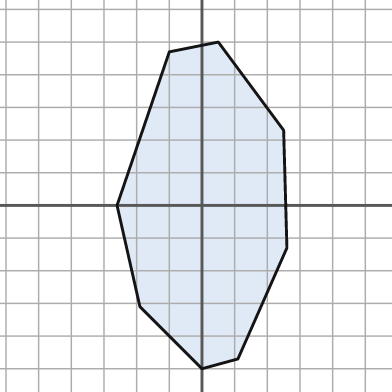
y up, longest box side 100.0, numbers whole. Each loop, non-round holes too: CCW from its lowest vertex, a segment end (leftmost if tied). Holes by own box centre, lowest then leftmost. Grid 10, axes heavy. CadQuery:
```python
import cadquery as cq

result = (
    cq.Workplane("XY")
    .moveTo(0.0, -50.0)
    .lineTo(11.0, -47.0)
    .lineTo(26.0, -13.0)
    .lineTo(25.0, 23.0)
    .lineTo(5.0, 50.0)
    .lineTo(-10.0, 47.0)
    .lineTo(-26.0, 0.0)
    .lineTo(-19.0, -31.0)
    .close()
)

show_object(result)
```